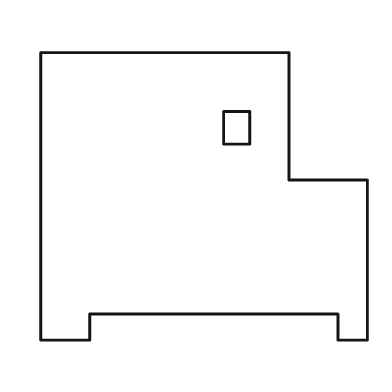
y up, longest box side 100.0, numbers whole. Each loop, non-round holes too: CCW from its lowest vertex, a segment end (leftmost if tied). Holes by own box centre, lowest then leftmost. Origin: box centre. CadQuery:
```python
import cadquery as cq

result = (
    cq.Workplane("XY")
    .moveTo(-50.0, -44.0)
    .lineTo(-35.0, -44.0)
    .lineTo(-35.0, -36.0)
    .lineTo(41.0, -36.0)
    .lineTo(41.0, -44.0)
    .lineTo(50.0, -44.0)
    .lineTo(50.0, 5.0)
    .lineTo(26.0, 5.0)
    .lineTo(26.0, 44.0)
    .lineTo(-50.0, 44.0)
    .close()
    .moveTo(6.0, 16.0)
    .lineTo(14.0, 16.0)
    .lineTo(14.0, 26.0)
    .lineTo(6.0, 26.0)
    .close()
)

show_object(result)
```